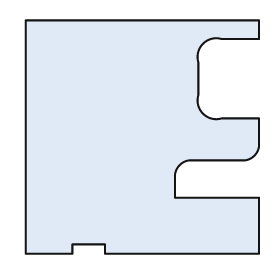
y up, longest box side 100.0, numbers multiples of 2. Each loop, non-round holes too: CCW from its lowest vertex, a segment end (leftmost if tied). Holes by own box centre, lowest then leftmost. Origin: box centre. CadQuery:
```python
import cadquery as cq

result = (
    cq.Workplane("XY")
    .moveTo(-50.0, -50.0)
    .lineTo(-30.0, -50.0)
    .lineTo(-30.0, -46.0)
    .lineTo(-16.0, -46.0)
    .lineTo(-16.0, -50.0)
    .lineTo(50.0, -50.0)
    .lineTo(50.0, -26.0)
    .lineTo(14.0, -26.0)
    .lineTo(14.0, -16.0)
    .threePointArc((16.0, -12.0), (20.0, -10.0))
    .lineTo(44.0, -10.0)
    .threePointArc((48.0, -8.0), (50.0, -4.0))
    .lineTo(50.0, 8.0)
    .lineTo(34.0, 8.0)
    .threePointArc((26.0, 10.0), (24.0, 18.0))
    .lineTo(24.0, 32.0)
    .threePointArc((26.0, 40.0), (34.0, 42.0))
    .lineTo(50.0, 42.0)
    .lineTo(50.0, 50.0)
    .lineTo(-50.0, 50.0)
    .close()
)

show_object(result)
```